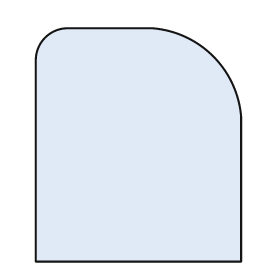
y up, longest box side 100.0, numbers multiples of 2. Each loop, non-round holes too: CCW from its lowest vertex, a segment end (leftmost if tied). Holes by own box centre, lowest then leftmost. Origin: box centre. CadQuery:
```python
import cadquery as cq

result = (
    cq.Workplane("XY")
    .moveTo(-44.0, -50.0)
    .lineTo(44.0, -50.0)
    .lineTo(44.0, 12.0)
    .threePointArc((32.0, 38.0), (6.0, 50.0))
    .lineTo(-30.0, 50.0)
    .threePointArc((-40.0, 46.0), (-44.0, 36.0))
    .close()
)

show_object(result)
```